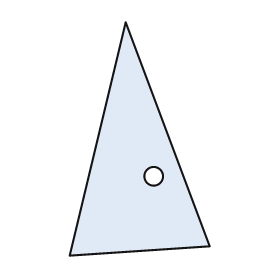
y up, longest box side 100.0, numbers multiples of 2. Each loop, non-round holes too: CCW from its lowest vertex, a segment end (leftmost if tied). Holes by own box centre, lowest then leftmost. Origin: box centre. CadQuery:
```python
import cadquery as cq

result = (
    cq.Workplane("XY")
    .moveTo(-30.0, -50.0)
    .lineTo(30.0, -46.0)
    .lineTo(-6.0, 50.0)
    .close()
    .moveTo(6.0, -16.0)
    .circle(4.0)
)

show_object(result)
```